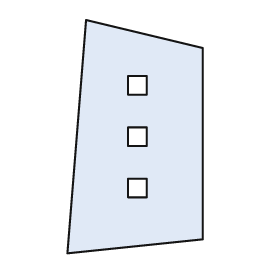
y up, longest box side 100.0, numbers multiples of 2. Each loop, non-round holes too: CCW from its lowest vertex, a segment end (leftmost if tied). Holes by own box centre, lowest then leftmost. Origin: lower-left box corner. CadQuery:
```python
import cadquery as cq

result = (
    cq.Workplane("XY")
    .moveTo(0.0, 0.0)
    .lineTo(58.0, 6.0)
    .lineTo(58.0, 88.0)
    .lineTo(8.0, 100.0)
    .close()
    .moveTo(26.0, 24.0)
    .lineTo(34.0, 24.0)
    .lineTo(34.0, 32.0)
    .lineTo(26.0, 32.0)
    .close()
    .moveTo(26.0, 46.0)
    .lineTo(34.0, 46.0)
    .lineTo(34.0, 54.0)
    .lineTo(26.0, 54.0)
    .close()
    .moveTo(26.0, 68.0)
    .lineTo(34.0, 68.0)
    .lineTo(34.0, 76.0)
    .lineTo(26.0, 76.0)
    .close()
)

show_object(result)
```